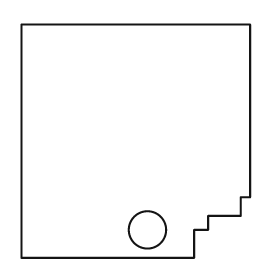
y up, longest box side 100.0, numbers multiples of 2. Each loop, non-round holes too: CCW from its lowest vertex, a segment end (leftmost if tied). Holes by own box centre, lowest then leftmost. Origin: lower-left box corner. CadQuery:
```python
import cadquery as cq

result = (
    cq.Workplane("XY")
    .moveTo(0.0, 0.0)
    .lineTo(74.0, 0.0)
    .lineTo(74.0, 12.0)
    .lineTo(80.0, 12.0)
    .lineTo(80.0, 18.0)
    .lineTo(94.0, 18.0)
    .lineTo(94.0, 26.0)
    .lineTo(98.0, 26.0)
    .lineTo(98.0, 100.0)
    .lineTo(0.0, 100.0)
    .close()
    .moveTo(54.0, 12.0)
    .circle(8.0)
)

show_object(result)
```